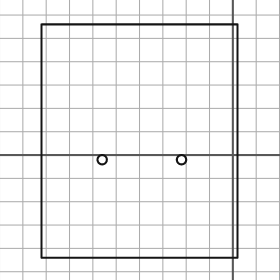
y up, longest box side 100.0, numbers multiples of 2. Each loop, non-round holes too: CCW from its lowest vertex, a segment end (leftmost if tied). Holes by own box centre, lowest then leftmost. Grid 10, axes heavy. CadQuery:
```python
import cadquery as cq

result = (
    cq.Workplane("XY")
    .moveTo(-82.0, -44.0)
    .lineTo(2.0, -44.0)
    .lineTo(2.0, 56.0)
    .lineTo(-82.0, 56.0)
    .close()
    .moveTo(-56.0, -2.0)
    .circle(2.0)
    .moveTo(-22.0, -2.0)
    .circle(2.0)
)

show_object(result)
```